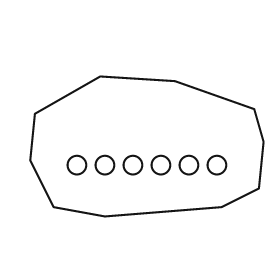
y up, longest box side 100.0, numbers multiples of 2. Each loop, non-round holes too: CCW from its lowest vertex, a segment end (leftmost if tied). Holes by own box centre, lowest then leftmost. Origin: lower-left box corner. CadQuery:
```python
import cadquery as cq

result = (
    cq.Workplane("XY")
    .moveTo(32.0, 0.0)
    .lineTo(82.0, 4.0)
    .lineTo(98.0, 12.0)
    .lineTo(100.0, 32.0)
    .lineTo(96.0, 46.0)
    .lineTo(62.0, 58.0)
    .lineTo(30.0, 60.0)
    .lineTo(2.0, 44.0)
    .lineTo(0.0, 24.0)
    .lineTo(10.0, 4.0)
    .close()
    .moveTo(20.0, 22.0)
    .circle(4.0)
    .moveTo(32.0, 22.0)
    .circle(4.0)
    .moveTo(44.0, 22.0)
    .circle(4.0)
    .moveTo(56.0, 22.0)
    .circle(4.0)
    .moveTo(68.0, 22.0)
    .circle(4.0)
    .moveTo(80.0, 22.0)
    .circle(4.0)
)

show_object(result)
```